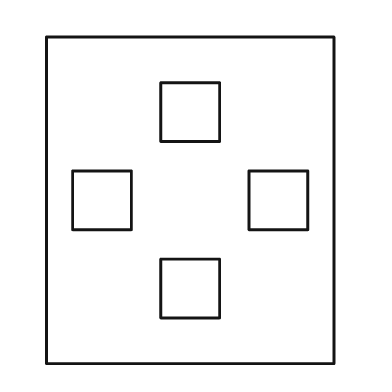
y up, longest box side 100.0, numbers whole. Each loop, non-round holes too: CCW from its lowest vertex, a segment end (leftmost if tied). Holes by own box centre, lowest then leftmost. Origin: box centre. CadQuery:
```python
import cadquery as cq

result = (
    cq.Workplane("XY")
    .moveTo(-44.0, -50.0)
    .lineTo(44.0, -50.0)
    .lineTo(44.0, 50.0)
    .lineTo(-44.0, 50.0)
    .close()
    .moveTo(-9.0, -36.0)
    .lineTo(9.0, -36.0)
    .lineTo(9.0, -18.0)
    .lineTo(-9.0, -18.0)
    .close()
    .moveTo(-36.0, -9.0)
    .lineTo(-18.0, -9.0)
    .lineTo(-18.0, 9.0)
    .lineTo(-36.0, 9.0)
    .close()
    .moveTo(18.0, -9.0)
    .lineTo(36.0, -9.0)
    .lineTo(36.0, 9.0)
    .lineTo(18.0, 9.0)
    .close()
    .moveTo(-9.0, 18.0)
    .lineTo(9.0, 18.0)
    .lineTo(9.0, 36.0)
    .lineTo(-9.0, 36.0)
    .close()
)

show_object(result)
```